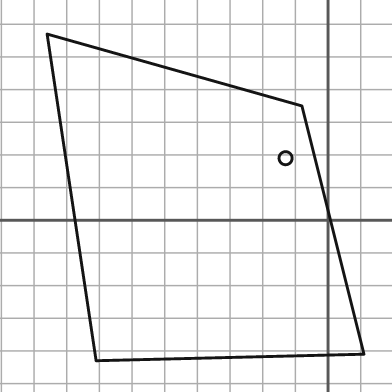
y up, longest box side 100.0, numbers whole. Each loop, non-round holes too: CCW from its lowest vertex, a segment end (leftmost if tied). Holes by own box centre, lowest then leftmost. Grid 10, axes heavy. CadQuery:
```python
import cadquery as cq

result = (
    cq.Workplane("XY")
    .moveTo(-71.0, -43.0)
    .lineTo(11.0, -41.0)
    .lineTo(-8.0, 35.0)
    .lineTo(-86.0, 57.0)
    .close()
    .moveTo(-13.0, 19.0)
    .circle(2.0)
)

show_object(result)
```